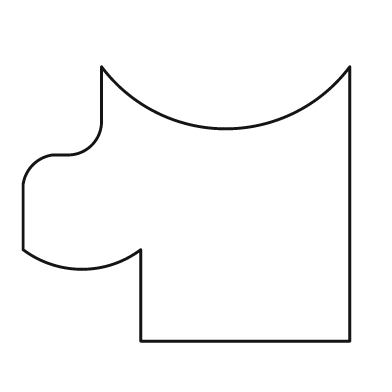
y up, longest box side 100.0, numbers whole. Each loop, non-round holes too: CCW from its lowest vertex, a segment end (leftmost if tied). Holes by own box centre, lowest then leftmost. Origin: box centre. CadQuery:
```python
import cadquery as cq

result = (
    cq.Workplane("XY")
    .moveTo(-14.0, -42.0)
    .lineTo(50.0, -42.0)
    .lineTo(50.0, 42.0)
    .threePointArc((12.0, 23.0), (-26.0, 42.0))
    .lineTo(-26.0, 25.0)
    .threePointArc((-29.0, 18.0), (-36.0, 15.0))
    .lineTo(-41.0, 15.0)
    .threePointArc((-47.0, 12.0), (-50.0, 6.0))
    .lineTo(-50.0, -14.0)
    .threePointArc((-32.0, -20.0), (-14.0, -14.0))
    .close()
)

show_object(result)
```